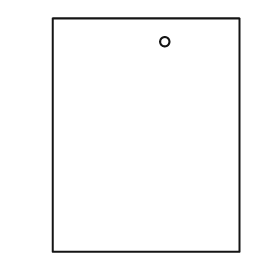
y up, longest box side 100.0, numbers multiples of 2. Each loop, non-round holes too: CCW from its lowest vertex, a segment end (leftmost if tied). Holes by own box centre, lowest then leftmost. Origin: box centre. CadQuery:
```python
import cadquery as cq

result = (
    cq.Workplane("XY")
    .moveTo(-40.0, -50.0)
    .lineTo(40.0, -50.0)
    .lineTo(40.0, 50.0)
    .lineTo(-40.0, 50.0)
    .close()
    .moveTo(8.0, 40.0)
    .circle(2.0)
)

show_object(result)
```